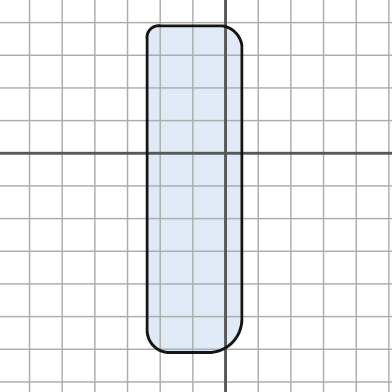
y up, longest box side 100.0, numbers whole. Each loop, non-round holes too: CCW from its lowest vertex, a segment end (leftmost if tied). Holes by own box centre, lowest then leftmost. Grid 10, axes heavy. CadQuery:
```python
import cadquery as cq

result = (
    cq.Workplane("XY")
    .moveTo(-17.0, -61.0)
    .lineTo(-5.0, -61.0)
    .threePointArc((2.0, -58.0), (5.0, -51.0))
    .lineTo(5.0, 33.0)
    .threePointArc((3.0, 37.0), (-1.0, 39.0))
    .lineTo(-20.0, 39.0)
    .threePointArc((-23.0, 38.0), (-24.0, 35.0))
    .lineTo(-24.0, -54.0)
    .threePointArc((-22.0, -59.0), (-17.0, -61.0))
    .close()
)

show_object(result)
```